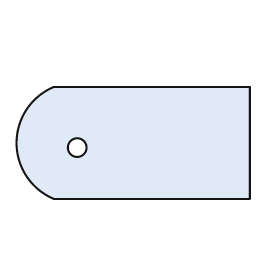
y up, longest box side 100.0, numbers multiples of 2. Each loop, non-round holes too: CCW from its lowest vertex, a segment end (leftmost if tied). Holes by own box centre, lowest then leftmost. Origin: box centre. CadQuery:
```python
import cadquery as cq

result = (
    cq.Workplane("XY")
    .moveTo(-34.0, -24.0)
    .lineTo(50.0, -24.0)
    .lineTo(50.0, 24.0)
    .lineTo(-34.0, 24.0)
    .threePointArc((-50.0, 0.0), (-34.0, -24.0))
    .close()
    .moveTo(-24.0, -2.0)
    .circle(4.0)
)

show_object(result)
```